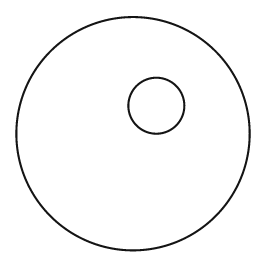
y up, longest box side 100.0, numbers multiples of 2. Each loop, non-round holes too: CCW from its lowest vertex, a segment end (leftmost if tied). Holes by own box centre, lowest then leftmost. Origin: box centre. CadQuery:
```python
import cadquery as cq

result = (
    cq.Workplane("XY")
    .moveTo(0.0, 0.0)
    .circle(50.0)
    .moveTo(10.0, 12.0)
    .circle(12.0)
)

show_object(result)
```